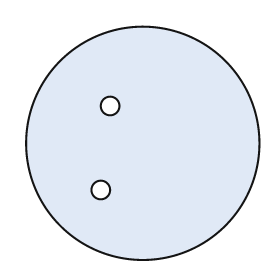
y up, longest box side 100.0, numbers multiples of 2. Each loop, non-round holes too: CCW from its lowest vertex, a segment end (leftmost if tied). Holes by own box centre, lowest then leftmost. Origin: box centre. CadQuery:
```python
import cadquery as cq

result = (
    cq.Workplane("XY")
    .moveTo(0.0, 0.0)
    .circle(50.0)
    .moveTo(-18.0, -20.0)
    .circle(4.0)
    .moveTo(-14.0, 16.0)
    .circle(4.0)
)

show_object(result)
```